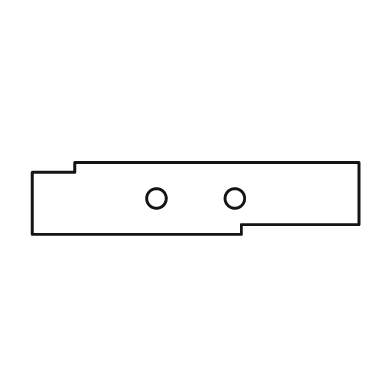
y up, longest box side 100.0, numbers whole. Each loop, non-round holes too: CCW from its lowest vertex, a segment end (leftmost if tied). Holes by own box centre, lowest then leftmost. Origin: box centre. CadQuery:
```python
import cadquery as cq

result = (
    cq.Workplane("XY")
    .moveTo(-50.0, -11.0)
    .lineTo(14.0, -11.0)
    .lineTo(14.0, -8.0)
    .lineTo(50.0, -8.0)
    .lineTo(50.0, 11.0)
    .lineTo(-37.0, 11.0)
    .lineTo(-37.0, 8.0)
    .lineTo(-50.0, 8.0)
    .close()
    .moveTo(-12.0, 0.0)
    .circle(3.0)
    .moveTo(12.0, 0.0)
    .circle(3.0)
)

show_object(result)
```